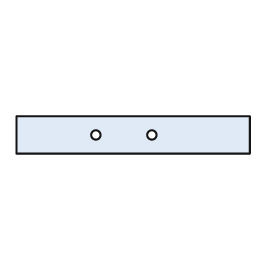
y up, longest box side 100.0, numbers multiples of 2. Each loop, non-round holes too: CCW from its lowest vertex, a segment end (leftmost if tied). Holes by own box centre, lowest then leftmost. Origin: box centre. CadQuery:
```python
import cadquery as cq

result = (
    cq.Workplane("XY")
    .moveTo(-50.0, -8.0)
    .lineTo(50.0, -8.0)
    .lineTo(50.0, 8.0)
    .lineTo(-50.0, 8.0)
    .close()
    .moveTo(-16.0, 0.0)
    .circle(2.0)
    .moveTo(8.0, 0.0)
    .circle(2.0)
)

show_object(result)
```